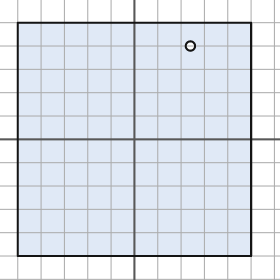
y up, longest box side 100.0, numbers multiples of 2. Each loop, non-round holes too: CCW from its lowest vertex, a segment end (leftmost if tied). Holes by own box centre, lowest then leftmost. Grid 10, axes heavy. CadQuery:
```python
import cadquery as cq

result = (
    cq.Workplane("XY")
    .moveTo(-50.0, -50.0)
    .lineTo(50.0, -50.0)
    .lineTo(50.0, 50.0)
    .lineTo(-50.0, 50.0)
    .close()
    .moveTo(24.0, 40.0)
    .circle(2.0)
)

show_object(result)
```